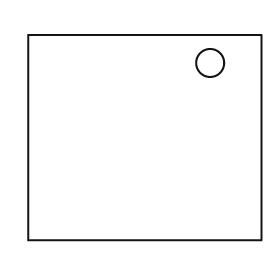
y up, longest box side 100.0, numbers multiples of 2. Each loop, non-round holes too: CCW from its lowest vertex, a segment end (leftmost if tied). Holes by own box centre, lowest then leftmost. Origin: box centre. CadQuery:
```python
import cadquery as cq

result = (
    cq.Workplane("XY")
    .moveTo(-50.0, -44.0)
    .lineTo(50.0, -44.0)
    .lineTo(50.0, 44.0)
    .lineTo(-50.0, 44.0)
    .close()
    .moveTo(28.0, 32.0)
    .circle(6.0)
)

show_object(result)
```